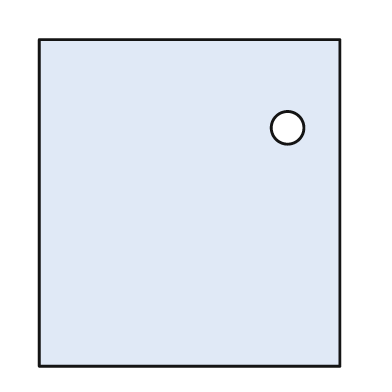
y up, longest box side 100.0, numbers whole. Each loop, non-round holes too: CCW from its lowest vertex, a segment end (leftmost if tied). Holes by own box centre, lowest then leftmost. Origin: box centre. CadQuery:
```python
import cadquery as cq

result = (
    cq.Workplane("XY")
    .moveTo(-46.0, -50.0)
    .lineTo(46.0, -50.0)
    .lineTo(46.0, 50.0)
    .lineTo(-46.0, 50.0)
    .close()
    .moveTo(30.0, 23.0)
    .circle(5.0)
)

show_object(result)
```